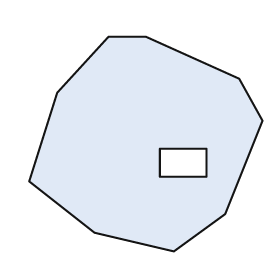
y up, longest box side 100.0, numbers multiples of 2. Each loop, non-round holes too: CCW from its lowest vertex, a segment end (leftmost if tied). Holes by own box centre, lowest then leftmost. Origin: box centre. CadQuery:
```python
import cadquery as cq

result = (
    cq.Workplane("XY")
    .moveTo(12.0, -46.0)
    .lineTo(34.0, -30.0)
    .lineTo(50.0, 10.0)
    .lineTo(40.0, 28.0)
    .lineTo(0.0, 46.0)
    .lineTo(-16.0, 46.0)
    .lineTo(-38.0, 22.0)
    .lineTo(-50.0, -16.0)
    .lineTo(-22.0, -38.0)
    .close()
    .moveTo(6.0, -14.0)
    .lineTo(26.0, -14.0)
    .lineTo(26.0, -2.0)
    .lineTo(6.0, -2.0)
    .close()
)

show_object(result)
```